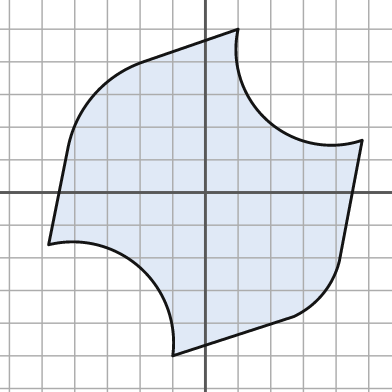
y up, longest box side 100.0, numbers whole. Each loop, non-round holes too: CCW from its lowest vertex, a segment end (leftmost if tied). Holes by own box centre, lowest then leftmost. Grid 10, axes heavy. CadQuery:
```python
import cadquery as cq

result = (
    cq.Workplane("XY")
    .moveTo(-10.0, -50.0)
    .lineTo(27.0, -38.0)
    .threePointArc((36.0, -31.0), (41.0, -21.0))
    .lineTo(48.0, 16.0)
    .threePointArc((19.0, 22.0), (10.0, 50.0))
    .lineTo(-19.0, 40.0)
    .threePointArc((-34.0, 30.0), (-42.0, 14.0))
    .lineTo(-48.0, -16.0)
    .threePointArc((-20.0, -23.0), (-10.0, -50.0))
    .close()
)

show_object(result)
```